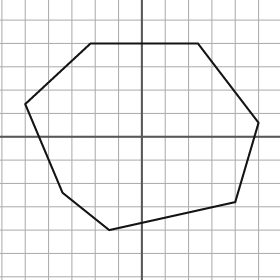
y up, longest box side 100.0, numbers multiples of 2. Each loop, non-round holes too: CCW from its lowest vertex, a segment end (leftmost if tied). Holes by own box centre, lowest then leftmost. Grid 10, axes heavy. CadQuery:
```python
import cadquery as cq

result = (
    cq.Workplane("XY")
    .moveTo(-14.0, -40.0)
    .lineTo(40.0, -28.0)
    .lineTo(50.0, 6.0)
    .lineTo(24.0, 40.0)
    .lineTo(-22.0, 40.0)
    .lineTo(-50.0, 14.0)
    .lineTo(-34.0, -24.0)
    .close()
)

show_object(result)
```